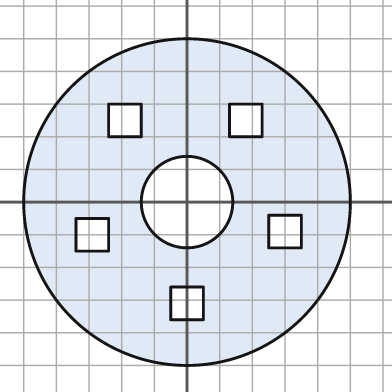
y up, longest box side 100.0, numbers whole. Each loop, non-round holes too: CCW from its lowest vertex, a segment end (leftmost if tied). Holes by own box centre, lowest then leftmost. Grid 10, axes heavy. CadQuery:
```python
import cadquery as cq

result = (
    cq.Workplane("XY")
    .moveTo(0.0, 0.0)
    .circle(50.0)
    .moveTo(-5.0, -36.0)
    .lineTo(5.0, -36.0)
    .lineTo(5.0, -26.0)
    .lineTo(-5.0, -26.0)
    .close()
    .moveTo(-34.0, -15.0)
    .lineTo(-24.0, -15.0)
    .lineTo(-24.0, -5.0)
    .lineTo(-34.0, -5.0)
    .close()
    .moveTo(25.0, -14.0)
    .lineTo(35.0, -14.0)
    .lineTo(35.0, -4.0)
    .lineTo(25.0, -4.0)
    .close()
    .moveTo(0.0, 0.0)
    .circle(14.0)
    .moveTo(-24.0, 20.0)
    .lineTo(-14.0, 20.0)
    .lineTo(-14.0, 30.0)
    .lineTo(-24.0, 30.0)
    .close()
    .moveTo(13.0, 20.0)
    .lineTo(23.0, 20.0)
    .lineTo(23.0, 30.0)
    .lineTo(13.0, 30.0)
    .close()
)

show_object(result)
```